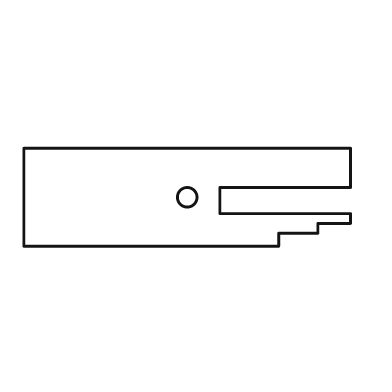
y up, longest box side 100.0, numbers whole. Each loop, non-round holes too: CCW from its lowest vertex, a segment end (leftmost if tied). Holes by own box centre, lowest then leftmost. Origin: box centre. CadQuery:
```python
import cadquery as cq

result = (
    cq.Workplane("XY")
    .moveTo(-50.0, -15.0)
    .lineTo(28.0, -15.0)
    .lineTo(28.0, -11.0)
    .lineTo(40.0, -11.0)
    .lineTo(40.0, -8.0)
    .lineTo(50.0, -8.0)
    .lineTo(50.0, -5.0)
    .lineTo(10.0, -5.0)
    .lineTo(10.0, 3.0)
    .lineTo(50.0, 3.0)
    .lineTo(50.0, 15.0)
    .lineTo(-50.0, 15.0)
    .close()
    .moveTo(0.0, 0.0)
    .circle(3.0)
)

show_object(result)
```